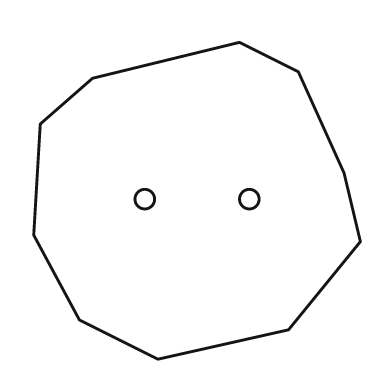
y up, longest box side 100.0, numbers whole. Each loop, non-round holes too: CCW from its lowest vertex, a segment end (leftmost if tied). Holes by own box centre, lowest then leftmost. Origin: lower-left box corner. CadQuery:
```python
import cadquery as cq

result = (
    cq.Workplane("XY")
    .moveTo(38.0, 0.0)
    .lineTo(78.0, 9.0)
    .lineTo(100.0, 36.0)
    .lineTo(95.0, 57.0)
    .lineTo(81.0, 88.0)
    .lineTo(63.0, 97.0)
    .lineTo(18.0, 86.0)
    .lineTo(2.0, 72.0)
    .lineTo(0.0, 38.0)
    .lineTo(14.0, 12.0)
    .close()
    .moveTo(34.0, 49.0)
    .circle(3.0)
    .moveTo(66.0, 49.0)
    .circle(3.0)
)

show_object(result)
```